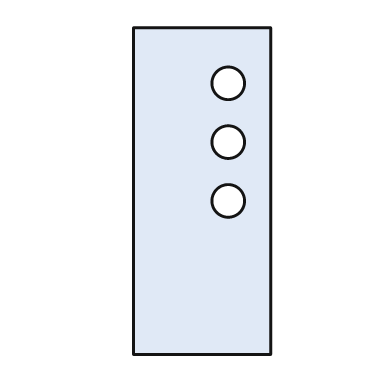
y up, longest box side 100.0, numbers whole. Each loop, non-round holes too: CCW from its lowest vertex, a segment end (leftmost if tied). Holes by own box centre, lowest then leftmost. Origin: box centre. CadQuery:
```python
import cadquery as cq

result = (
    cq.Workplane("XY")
    .moveTo(-21.0, -50.0)
    .lineTo(21.0, -50.0)
    .lineTo(21.0, 50.0)
    .lineTo(-21.0, 50.0)
    .close()
    .moveTo(8.0, -3.0)
    .circle(5.0)
    .moveTo(8.0, 15.0)
    .circle(5.0)
    .moveTo(8.0, 33.0)
    .circle(5.0)
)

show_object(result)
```